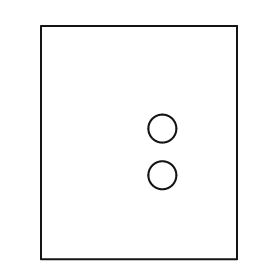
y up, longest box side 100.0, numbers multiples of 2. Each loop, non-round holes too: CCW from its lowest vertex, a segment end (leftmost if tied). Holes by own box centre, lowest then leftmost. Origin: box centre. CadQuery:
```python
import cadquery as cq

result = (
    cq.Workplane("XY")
    .moveTo(-42.0, -50.0)
    .lineTo(42.0, -50.0)
    .lineTo(42.0, 50.0)
    .lineTo(-42.0, 50.0)
    .close()
    .moveTo(10.0, -14.0)
    .circle(6.0)
    .moveTo(10.0, 6.0)
    .circle(6.0)
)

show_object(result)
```